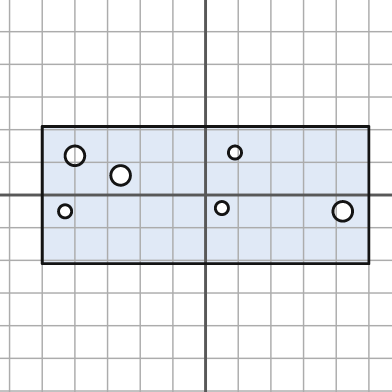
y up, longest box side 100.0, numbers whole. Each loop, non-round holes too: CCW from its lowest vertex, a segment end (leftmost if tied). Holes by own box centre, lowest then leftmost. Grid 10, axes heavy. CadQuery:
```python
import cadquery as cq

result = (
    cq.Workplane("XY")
    .moveTo(-50.0, -21.0)
    .lineTo(50.0, -21.0)
    .lineTo(50.0, 21.0)
    .lineTo(-50.0, 21.0)
    .close()
    .moveTo(-43.0, -5.0)
    .circle(2.0)
    .moveTo(42.0, -5.0)
    .circle(3.0)
    .moveTo(5.0, -4.0)
    .circle(2.0)
    .moveTo(-26.0, 6.0)
    .circle(3.0)
    .moveTo(-40.0, 12.0)
    .circle(3.0)
    .moveTo(9.0, 13.0)
    .circle(2.0)
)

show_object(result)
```